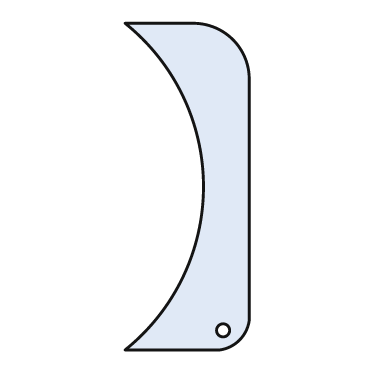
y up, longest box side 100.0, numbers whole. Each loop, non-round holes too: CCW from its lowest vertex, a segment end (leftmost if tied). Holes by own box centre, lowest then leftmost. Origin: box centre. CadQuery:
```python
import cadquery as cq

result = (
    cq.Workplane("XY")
    .moveTo(-19.0, -50.0)
    .lineTo(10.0, -50.0)
    .threePointArc((16.0, -47.0), (19.0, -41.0))
    .lineTo(19.0, 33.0)
    .threePointArc((14.0, 45.0), (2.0, 50.0))
    .lineTo(-19.0, 50.0)
    .threePointArc((5.0, 0.0), (-19.0, -50.0))
    .close()
    .moveTo(11.0, -44.0)
    .circle(2.0)
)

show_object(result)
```